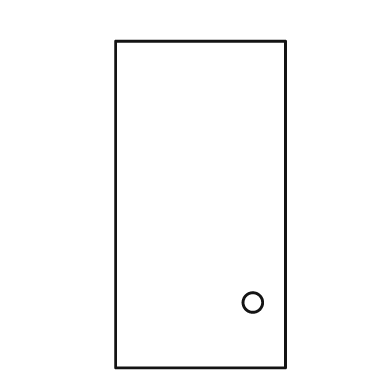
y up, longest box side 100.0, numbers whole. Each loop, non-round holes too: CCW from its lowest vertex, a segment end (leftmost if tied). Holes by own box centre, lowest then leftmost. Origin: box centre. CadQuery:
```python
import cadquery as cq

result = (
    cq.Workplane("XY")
    .moveTo(-26.0, -50.0)
    .lineTo(26.0, -50.0)
    .lineTo(26.0, 50.0)
    .lineTo(-26.0, 50.0)
    .close()
    .moveTo(16.0, -30.0)
    .circle(3.0)
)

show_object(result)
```